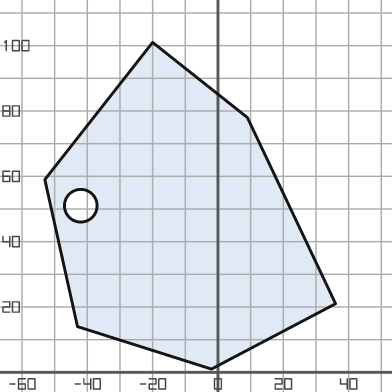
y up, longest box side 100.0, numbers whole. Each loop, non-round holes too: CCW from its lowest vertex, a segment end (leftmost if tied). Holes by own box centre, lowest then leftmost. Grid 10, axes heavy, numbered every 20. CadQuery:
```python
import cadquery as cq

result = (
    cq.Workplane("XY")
    .moveTo(-2.0, 1.0)
    .lineTo(36.0, 21.0)
    .lineTo(9.0, 78.0)
    .lineTo(-20.0, 101.0)
    .lineTo(-53.0, 59.0)
    .lineTo(-43.0, 14.0)
    .close()
    .moveTo(-42.0, 51.0)
    .circle(5.0)
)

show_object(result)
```